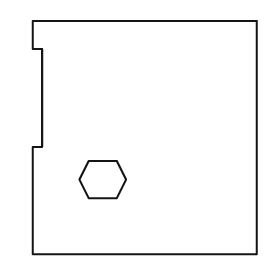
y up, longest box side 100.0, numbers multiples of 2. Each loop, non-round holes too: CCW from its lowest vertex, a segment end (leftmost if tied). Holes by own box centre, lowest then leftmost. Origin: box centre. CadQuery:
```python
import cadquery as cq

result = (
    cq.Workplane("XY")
    .moveTo(-48.0, -50.0)
    .lineTo(48.0, -50.0)
    .lineTo(48.0, 50.0)
    .lineTo(-48.0, 50.0)
    .lineTo(-48.0, 38.0)
    .lineTo(-44.0, 38.0)
    .lineTo(-44.0, -4.0)
    .lineTo(-48.0, -4.0)
    .close()
    .moveTo(-24.0, -26.0)
    .lineTo(-12.0, -26.0)
    .lineTo(-8.0, -18.0)
    .lineTo(-12.0, -10.0)
    .lineTo(-24.0, -10.0)
    .lineTo(-28.0, -18.0)
    .close()
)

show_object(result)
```